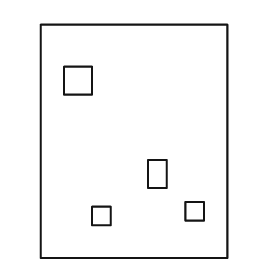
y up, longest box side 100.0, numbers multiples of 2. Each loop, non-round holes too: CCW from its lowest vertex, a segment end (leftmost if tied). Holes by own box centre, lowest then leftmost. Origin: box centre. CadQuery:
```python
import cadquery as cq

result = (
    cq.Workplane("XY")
    .moveTo(-40.0, -50.0)
    .lineTo(40.0, -50.0)
    .lineTo(40.0, 50.0)
    .lineTo(-40.0, 50.0)
    .close()
    .moveTo(-18.0, -36.0)
    .lineTo(-10.0, -36.0)
    .lineTo(-10.0, -28.0)
    .lineTo(-18.0, -28.0)
    .close()
    .moveTo(22.0, -34.0)
    .lineTo(30.0, -34.0)
    .lineTo(30.0, -26.0)
    .lineTo(22.0, -26.0)
    .close()
    .moveTo(6.0, -20.0)
    .lineTo(14.0, -20.0)
    .lineTo(14.0, -8.0)
    .lineTo(6.0, -8.0)
    .close()
    .moveTo(-30.0, 20.0)
    .lineTo(-18.0, 20.0)
    .lineTo(-18.0, 32.0)
    .lineTo(-30.0, 32.0)
    .close()
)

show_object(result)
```